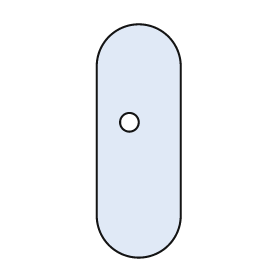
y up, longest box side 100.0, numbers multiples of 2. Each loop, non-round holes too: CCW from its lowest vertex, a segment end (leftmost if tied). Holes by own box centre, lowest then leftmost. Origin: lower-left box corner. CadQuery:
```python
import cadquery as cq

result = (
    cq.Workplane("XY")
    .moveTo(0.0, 18.0)
    .threePointArc((18.0, 0.0), (36.0, 18.0))
    .lineTo(36.0, 82.0)
    .threePointArc((18.0, 100.0), (0.0, 82.0))
    .close()
    .moveTo(14.0, 58.0)
    .circle(4.0)
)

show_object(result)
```